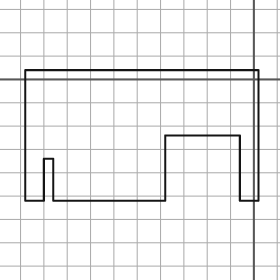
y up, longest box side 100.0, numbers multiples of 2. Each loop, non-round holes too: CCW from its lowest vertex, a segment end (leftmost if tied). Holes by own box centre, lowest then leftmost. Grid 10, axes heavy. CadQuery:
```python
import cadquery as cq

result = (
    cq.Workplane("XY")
    .moveTo(-98.0, -52.0)
    .lineTo(-90.0, -52.0)
    .lineTo(-90.0, -34.0)
    .lineTo(-86.0, -34.0)
    .lineTo(-86.0, -52.0)
    .lineTo(-38.0, -52.0)
    .lineTo(-38.0, -24.0)
    .lineTo(-6.0, -24.0)
    .lineTo(-6.0, -52.0)
    .lineTo(2.0, -52.0)
    .lineTo(2.0, 4.0)
    .lineTo(-98.0, 4.0)
    .close()
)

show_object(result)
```